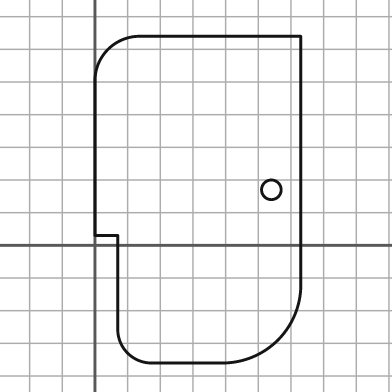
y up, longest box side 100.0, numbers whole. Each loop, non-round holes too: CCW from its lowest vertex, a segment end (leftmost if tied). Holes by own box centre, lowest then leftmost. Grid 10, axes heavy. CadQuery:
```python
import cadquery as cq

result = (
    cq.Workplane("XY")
    .moveTo(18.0, -36.0)
    .lineTo(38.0, -36.0)
    .threePointArc((56.0, -29.0), (63.0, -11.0))
    .lineTo(63.0, 64.0)
    .lineTo(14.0, 64.0)
    .threePointArc((4.0, 60.0), (0.0, 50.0))
    .lineTo(0.0, 3.0)
    .lineTo(7.0, 3.0)
    .lineTo(7.0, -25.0)
    .threePointArc((10.0, -33.0), (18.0, -36.0))
    .close()
    .moveTo(54.0, 17.0)
    .circle(3.0)
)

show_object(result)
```